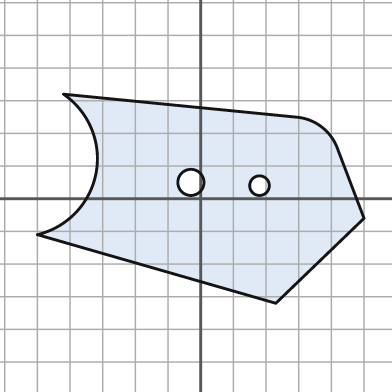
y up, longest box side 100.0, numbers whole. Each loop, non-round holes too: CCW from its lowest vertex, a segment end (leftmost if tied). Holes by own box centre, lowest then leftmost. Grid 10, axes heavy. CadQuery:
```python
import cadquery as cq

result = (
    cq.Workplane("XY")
    .moveTo(23.0, -32.0)
    .lineTo(50.0, -6.0)
    .lineTo(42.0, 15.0)
    .threePointArc((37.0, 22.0), (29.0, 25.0))
    .lineTo(-42.0, 32.0)
    .threePointArc((-32.0, 8.0), (-50.0, -11.0))
    .close()
    .moveTo(18.0, 4.0)
    .circle(3.0)
    .moveTo(-3.0, 5.0)
    .circle(4.0)
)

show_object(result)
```